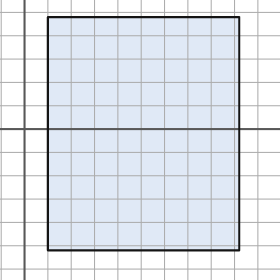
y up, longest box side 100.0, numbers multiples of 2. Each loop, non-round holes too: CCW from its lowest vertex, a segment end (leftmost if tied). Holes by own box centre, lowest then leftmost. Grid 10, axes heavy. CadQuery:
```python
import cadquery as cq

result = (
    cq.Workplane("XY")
    .moveTo(10.0, -52.0)
    .lineTo(92.0, -52.0)
    .lineTo(92.0, 48.0)
    .lineTo(10.0, 48.0)
    .close()
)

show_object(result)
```